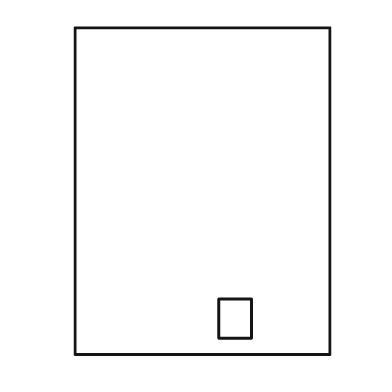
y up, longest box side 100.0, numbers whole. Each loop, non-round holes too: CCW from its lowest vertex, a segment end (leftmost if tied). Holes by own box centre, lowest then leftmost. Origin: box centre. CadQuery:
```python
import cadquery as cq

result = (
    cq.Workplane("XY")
    .moveTo(-39.0, -50.0)
    .lineTo(39.0, -50.0)
    .lineTo(39.0, 50.0)
    .lineTo(-39.0, 50.0)
    .close()
    .moveTo(5.0, -45.0)
    .lineTo(15.0, -45.0)
    .lineTo(15.0, -33.0)
    .lineTo(5.0, -33.0)
    .close()
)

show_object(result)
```